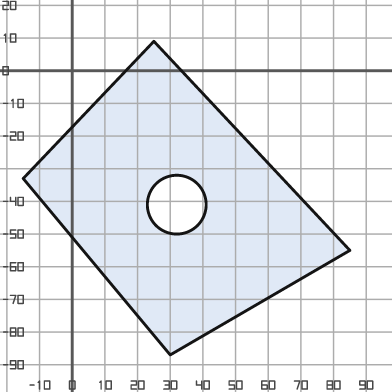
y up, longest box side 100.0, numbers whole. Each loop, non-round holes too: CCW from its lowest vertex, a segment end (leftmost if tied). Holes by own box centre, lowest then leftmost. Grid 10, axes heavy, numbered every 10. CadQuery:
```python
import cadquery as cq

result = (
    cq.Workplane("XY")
    .moveTo(30.0, -87.0)
    .lineTo(85.0, -55.0)
    .lineTo(25.0, 9.0)
    .lineTo(-15.0, -33.0)
    .close()
    .moveTo(32.0, -41.0)
    .circle(9.0)
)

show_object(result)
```